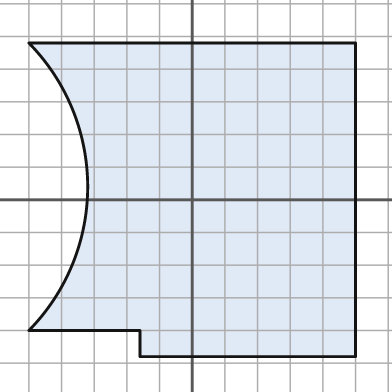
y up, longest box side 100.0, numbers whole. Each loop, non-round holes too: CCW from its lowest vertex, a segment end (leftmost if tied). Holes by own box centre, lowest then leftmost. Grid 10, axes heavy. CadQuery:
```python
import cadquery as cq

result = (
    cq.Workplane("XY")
    .moveTo(-16.0, -48.0)
    .lineTo(50.0, -48.0)
    .lineTo(50.0, 48.0)
    .lineTo(-50.0, 48.0)
    .threePointArc((-32.0, 4.0), (-50.0, -40.0))
    .lineTo(-16.0, -40.0)
    .close()
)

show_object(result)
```